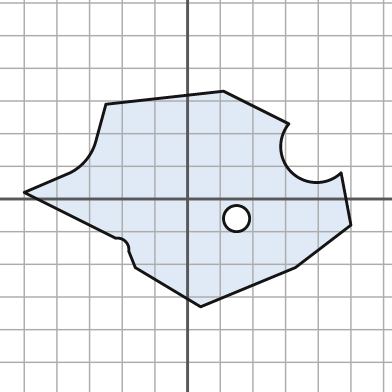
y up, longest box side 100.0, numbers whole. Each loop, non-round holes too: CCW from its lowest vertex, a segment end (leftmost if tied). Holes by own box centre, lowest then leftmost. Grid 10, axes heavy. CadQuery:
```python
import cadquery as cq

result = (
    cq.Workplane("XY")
    .moveTo(4.0, -33.0)
    .lineTo(33.0, -21.0)
    .lineTo(50.0, -8.0)
    .lineTo(47.0, 8.0)
    .threePointArc((32.0, 8.0), (31.0, 23.0))
    .lineTo(11.0, 33.0)
    .lineTo(-25.0, 29.0)
    .lineTo(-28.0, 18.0)
    .threePointArc((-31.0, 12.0), (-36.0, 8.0))
    .lineTo(-50.0, 2.0)
    .lineTo(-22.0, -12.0)
    .threePointArc((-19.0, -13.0), (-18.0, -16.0))
    .lineTo(-16.0, -21.0)
    .close()
    .moveTo(15.0, -6.0)
    .circle(4.0)
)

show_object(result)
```